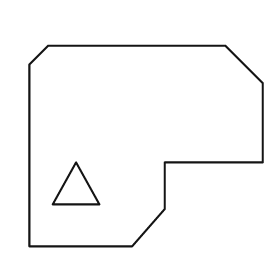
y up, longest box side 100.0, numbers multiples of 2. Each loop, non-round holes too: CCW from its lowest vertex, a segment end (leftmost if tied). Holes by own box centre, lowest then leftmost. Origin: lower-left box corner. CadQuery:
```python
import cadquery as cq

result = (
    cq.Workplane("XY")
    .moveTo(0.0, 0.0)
    .lineTo(44.0, 0.0)
    .lineTo(58.0, 16.0)
    .lineTo(58.0, 36.0)
    .lineTo(100.0, 36.0)
    .lineTo(100.0, 70.0)
    .lineTo(84.0, 86.0)
    .lineTo(8.0, 86.0)
    .lineTo(0.0, 78.0)
    .close()
    .moveTo(10.0, 18.0)
    .lineTo(30.0, 18.0)
    .lineTo(20.0, 36.0)
    .close()
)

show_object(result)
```